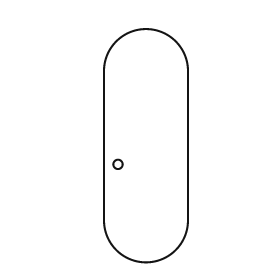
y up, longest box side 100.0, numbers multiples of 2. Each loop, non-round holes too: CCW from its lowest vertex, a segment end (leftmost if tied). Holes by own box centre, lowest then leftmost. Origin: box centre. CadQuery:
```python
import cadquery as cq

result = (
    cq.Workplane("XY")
    .moveTo(-18.0, -32.0)
    .threePointArc((0.0, -50.0), (18.0, -32.0))
    .lineTo(18.0, 32.0)
    .threePointArc((0.0, 50.0), (-18.0, 32.0))
    .close()
    .moveTo(-12.0, -8.0)
    .circle(2.0)
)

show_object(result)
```